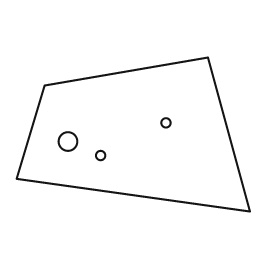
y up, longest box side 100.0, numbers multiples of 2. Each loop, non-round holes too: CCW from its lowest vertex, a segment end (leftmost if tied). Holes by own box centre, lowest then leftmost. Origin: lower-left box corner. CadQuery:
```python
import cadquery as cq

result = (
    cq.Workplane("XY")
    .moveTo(100.0, 0.0)
    .lineTo(82.0, 66.0)
    .lineTo(12.0, 54.0)
    .lineTo(0.0, 14.0)
    .close()
    .moveTo(36.0, 24.0)
    .circle(2.0)
    .moveTo(22.0, 30.0)
    .circle(4.0)
    .moveTo(64.0, 38.0)
    .circle(2.0)
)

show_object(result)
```